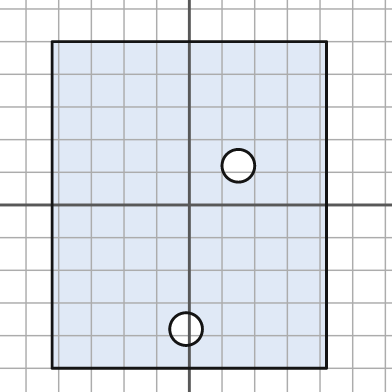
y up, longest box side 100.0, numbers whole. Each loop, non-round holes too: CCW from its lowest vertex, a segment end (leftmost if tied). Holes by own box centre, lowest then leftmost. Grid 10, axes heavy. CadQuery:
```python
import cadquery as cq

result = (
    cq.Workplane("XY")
    .moveTo(-42.0, -50.0)
    .lineTo(42.0, -50.0)
    .lineTo(42.0, 50.0)
    .lineTo(-42.0, 50.0)
    .close()
    .moveTo(-1.0, -38.0)
    .circle(5.0)
    .moveTo(15.0, 12.0)
    .circle(5.0)
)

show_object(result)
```